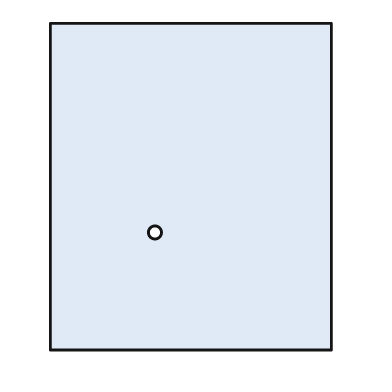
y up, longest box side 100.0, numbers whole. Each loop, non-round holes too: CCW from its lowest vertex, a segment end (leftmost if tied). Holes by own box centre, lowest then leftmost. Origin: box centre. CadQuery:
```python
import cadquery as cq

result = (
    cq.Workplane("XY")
    .moveTo(-43.0, -50.0)
    .lineTo(43.0, -50.0)
    .lineTo(43.0, 50.0)
    .lineTo(-43.0, 50.0)
    .close()
    .moveTo(-11.0, -14.0)
    .circle(2.0)
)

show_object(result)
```